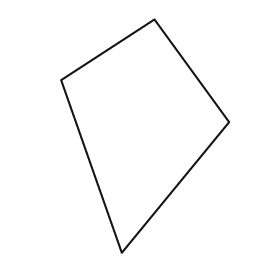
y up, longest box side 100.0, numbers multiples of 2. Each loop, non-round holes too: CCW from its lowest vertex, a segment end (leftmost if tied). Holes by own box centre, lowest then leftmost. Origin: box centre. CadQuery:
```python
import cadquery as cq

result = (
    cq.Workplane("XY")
    .moveTo(-10.0, -50.0)
    .lineTo(36.0, 6.0)
    .lineTo(4.0, 50.0)
    .lineTo(-36.0, 24.0)
    .close()
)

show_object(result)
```